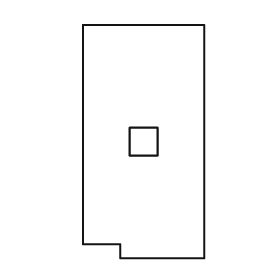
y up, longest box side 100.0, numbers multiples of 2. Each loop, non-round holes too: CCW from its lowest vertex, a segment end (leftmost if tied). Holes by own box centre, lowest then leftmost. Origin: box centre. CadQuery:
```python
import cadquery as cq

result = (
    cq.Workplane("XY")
    .moveTo(-10.0, -50.0)
    .lineTo(26.0, -50.0)
    .lineTo(26.0, 50.0)
    .lineTo(-26.0, 50.0)
    .lineTo(-26.0, -44.0)
    .lineTo(-10.0, -44.0)
    .close()
    .moveTo(-6.0, -6.0)
    .lineTo(6.0, -6.0)
    .lineTo(6.0, 6.0)
    .lineTo(-6.0, 6.0)
    .close()
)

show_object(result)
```